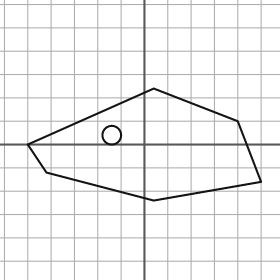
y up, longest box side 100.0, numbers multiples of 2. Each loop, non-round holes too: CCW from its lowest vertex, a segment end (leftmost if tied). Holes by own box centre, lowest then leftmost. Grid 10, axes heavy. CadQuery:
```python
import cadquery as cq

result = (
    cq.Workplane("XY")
    .moveTo(4.0, -24.0)
    .lineTo(50.0, -16.0)
    .lineTo(40.0, 10.0)
    .lineTo(4.0, 24.0)
    .lineTo(-50.0, 0.0)
    .lineTo(-42.0, -12.0)
    .close()
    .moveTo(-14.0, 4.0)
    .circle(4.0)
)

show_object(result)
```